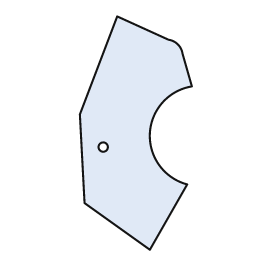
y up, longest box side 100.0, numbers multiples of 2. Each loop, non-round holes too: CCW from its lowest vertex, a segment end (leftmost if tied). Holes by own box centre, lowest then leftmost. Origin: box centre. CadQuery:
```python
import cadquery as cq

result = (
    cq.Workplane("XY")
    .moveTo(6.0, -50.0)
    .lineTo(22.0, -22.0)
    .threePointArc((6.0, 0.0), (24.0, 20.0))
    .lineTo(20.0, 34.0)
    .threePointArc((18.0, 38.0), (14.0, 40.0))
    .lineTo(-8.0, 50.0)
    .lineTo(-24.0, 8.0)
    .lineTo(-22.0, -30.0)
    .close()
    .moveTo(-14.0, -6.0)
    .circle(2.0)
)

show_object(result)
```